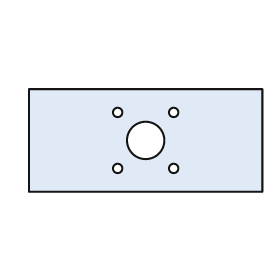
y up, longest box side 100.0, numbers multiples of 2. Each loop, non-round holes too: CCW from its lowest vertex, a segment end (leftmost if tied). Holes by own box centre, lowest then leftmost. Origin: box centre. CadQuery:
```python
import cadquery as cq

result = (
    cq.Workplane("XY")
    .moveTo(-50.0, -22.0)
    .lineTo(50.0, -22.0)
    .lineTo(50.0, 22.0)
    .lineTo(-50.0, 22.0)
    .close()
    .moveTo(-12.0, -12.0)
    .circle(2.0)
    .moveTo(12.0, -12.0)
    .circle(2.0)
    .moveTo(0.0, 0.0)
    .circle(8.0)
    .moveTo(-12.0, 12.0)
    .circle(2.0)
    .moveTo(12.0, 12.0)
    .circle(2.0)
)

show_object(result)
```